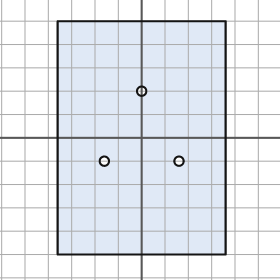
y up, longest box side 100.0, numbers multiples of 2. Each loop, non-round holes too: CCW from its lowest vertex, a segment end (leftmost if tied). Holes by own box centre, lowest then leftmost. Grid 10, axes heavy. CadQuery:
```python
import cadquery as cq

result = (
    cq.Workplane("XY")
    .moveTo(-36.0, -50.0)
    .lineTo(36.0, -50.0)
    .lineTo(36.0, 50.0)
    .lineTo(-36.0, 50.0)
    .close()
    .moveTo(-16.0, -10.0)
    .circle(2.0)
    .moveTo(16.0, -10.0)
    .circle(2.0)
    .moveTo(0.0, 20.0)
    .circle(2.0)
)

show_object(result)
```